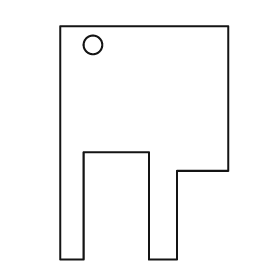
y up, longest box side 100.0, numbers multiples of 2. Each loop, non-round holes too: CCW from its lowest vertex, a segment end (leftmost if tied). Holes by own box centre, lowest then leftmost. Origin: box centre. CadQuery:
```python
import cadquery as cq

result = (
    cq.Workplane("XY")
    .moveTo(-36.0, -50.0)
    .lineTo(-26.0, -50.0)
    .lineTo(-26.0, -4.0)
    .lineTo(2.0, -4.0)
    .lineTo(2.0, -50.0)
    .lineTo(14.0, -50.0)
    .lineTo(14.0, -12.0)
    .lineTo(36.0, -12.0)
    .lineTo(36.0, 50.0)
    .lineTo(-36.0, 50.0)
    .close()
    .moveTo(-22.0, 42.0)
    .circle(4.0)
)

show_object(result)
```